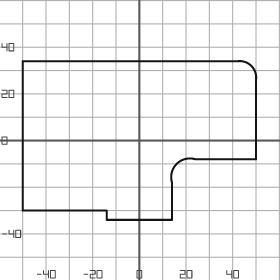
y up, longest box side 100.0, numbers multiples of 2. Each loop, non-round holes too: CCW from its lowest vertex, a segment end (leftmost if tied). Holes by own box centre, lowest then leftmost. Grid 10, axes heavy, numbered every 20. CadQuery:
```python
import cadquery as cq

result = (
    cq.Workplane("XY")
    .moveTo(-14.0, -34.0)
    .lineTo(14.0, -34.0)
    .lineTo(14.0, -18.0)
    .threePointArc((16.0, -10.0), (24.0, -8.0))
    .lineTo(50.0, -8.0)
    .lineTo(50.0, 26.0)
    .threePointArc((48.0, 32.0), (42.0, 34.0))
    .lineTo(-50.0, 34.0)
    .lineTo(-50.0, -30.0)
    .lineTo(-14.0, -30.0)
    .close()
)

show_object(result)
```